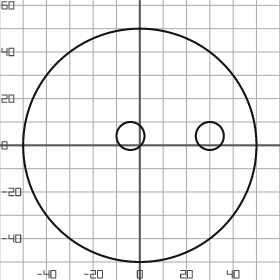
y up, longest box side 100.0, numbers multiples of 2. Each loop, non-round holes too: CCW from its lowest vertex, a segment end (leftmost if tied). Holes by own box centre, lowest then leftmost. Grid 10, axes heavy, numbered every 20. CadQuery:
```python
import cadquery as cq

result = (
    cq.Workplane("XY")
    .moveTo(0.0, 0.0)
    .circle(50.0)
    .moveTo(-4.0, 4.0)
    .circle(6.0)
    .moveTo(30.0, 4.0)
    .circle(6.0)
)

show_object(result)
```